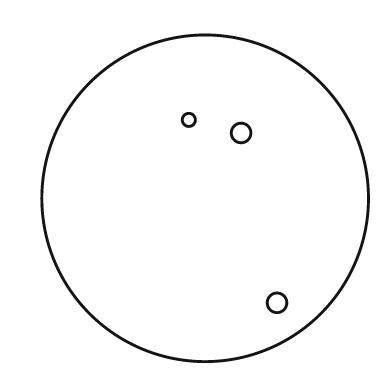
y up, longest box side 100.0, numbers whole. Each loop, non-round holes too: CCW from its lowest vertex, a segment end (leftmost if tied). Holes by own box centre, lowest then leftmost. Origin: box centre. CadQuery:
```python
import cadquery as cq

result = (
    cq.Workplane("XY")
    .moveTo(0.0, 0.0)
    .circle(50.0)
    .moveTo(22.0, -32.0)
    .circle(3.0)
    .moveTo(11.0, 20.0)
    .circle(3.0)
    .moveTo(-5.0, 24.0)
    .circle(2.0)
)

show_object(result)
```